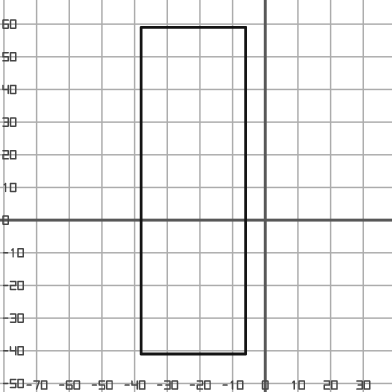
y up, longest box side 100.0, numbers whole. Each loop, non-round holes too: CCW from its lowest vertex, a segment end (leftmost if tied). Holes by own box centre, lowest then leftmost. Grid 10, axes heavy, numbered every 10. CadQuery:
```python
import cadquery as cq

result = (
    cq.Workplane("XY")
    .moveTo(-38.0, -41.0)
    .lineTo(-6.0, -41.0)
    .lineTo(-6.0, 59.0)
    .lineTo(-38.0, 59.0)
    .close()
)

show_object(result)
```